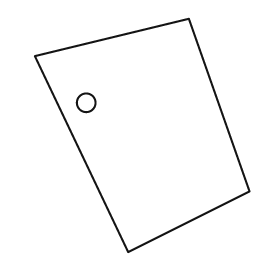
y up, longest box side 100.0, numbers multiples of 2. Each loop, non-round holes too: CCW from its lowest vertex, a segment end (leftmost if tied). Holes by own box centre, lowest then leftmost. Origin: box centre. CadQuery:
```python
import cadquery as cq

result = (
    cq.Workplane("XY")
    .moveTo(-6.0, -50.0)
    .lineTo(46.0, -24.0)
    .lineTo(20.0, 50.0)
    .lineTo(-46.0, 34.0)
    .close()
    .moveTo(-24.0, 14.0)
    .circle(4.0)
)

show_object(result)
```